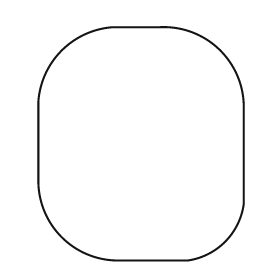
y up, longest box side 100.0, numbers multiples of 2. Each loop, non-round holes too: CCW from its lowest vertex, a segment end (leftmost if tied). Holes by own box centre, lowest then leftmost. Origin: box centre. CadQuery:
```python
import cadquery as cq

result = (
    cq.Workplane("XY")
    .moveTo(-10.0, -50.0)
    .lineTo(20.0, -50.0)
    .threePointArc((36.0, -42.0), (44.0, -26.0))
    .lineTo(44.0, 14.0)
    .threePointArc((34.0, 40.0), (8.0, 50.0))
    .lineTo(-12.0, 50.0)
    .threePointArc((-34.0, 40.0), (-44.0, 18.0))
    .lineTo(-44.0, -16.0)
    .threePointArc((-34.0, -40.0), (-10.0, -50.0))
    .close()
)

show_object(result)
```